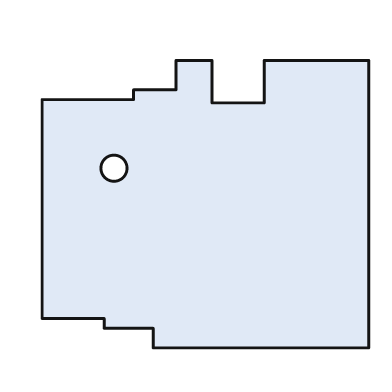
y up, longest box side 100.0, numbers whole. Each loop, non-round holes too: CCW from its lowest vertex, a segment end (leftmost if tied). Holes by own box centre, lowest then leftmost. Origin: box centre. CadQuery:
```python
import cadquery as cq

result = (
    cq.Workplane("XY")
    .moveTo(-16.0, -44.0)
    .lineTo(50.0, -44.0)
    .lineTo(50.0, 44.0)
    .lineTo(18.0, 44.0)
    .lineTo(18.0, 31.0)
    .lineTo(2.0, 31.0)
    .lineTo(2.0, 44.0)
    .lineTo(-9.0, 44.0)
    .lineTo(-9.0, 35.0)
    .lineTo(-22.0, 35.0)
    .lineTo(-22.0, 32.0)
    .lineTo(-50.0, 32.0)
    .lineTo(-50.0, -35.0)
    .lineTo(-31.0, -35.0)
    .lineTo(-31.0, -38.0)
    .lineTo(-16.0, -38.0)
    .close()
    .moveTo(-28.0, 11.0)
    .circle(4.0)
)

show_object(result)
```